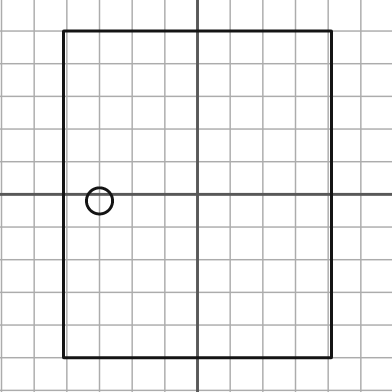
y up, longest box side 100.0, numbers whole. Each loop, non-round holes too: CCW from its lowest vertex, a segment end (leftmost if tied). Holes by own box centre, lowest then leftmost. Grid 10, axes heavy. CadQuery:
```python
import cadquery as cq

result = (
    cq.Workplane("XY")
    .moveTo(-41.0, -50.0)
    .lineTo(41.0, -50.0)
    .lineTo(41.0, 50.0)
    .lineTo(-41.0, 50.0)
    .close()
    .moveTo(-30.0, -2.0)
    .circle(4.0)
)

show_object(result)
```